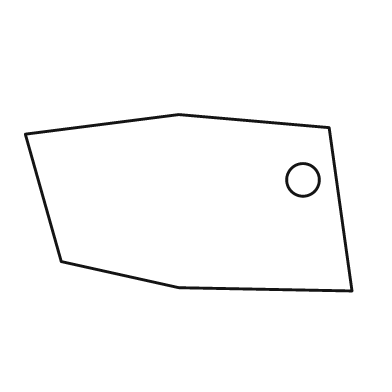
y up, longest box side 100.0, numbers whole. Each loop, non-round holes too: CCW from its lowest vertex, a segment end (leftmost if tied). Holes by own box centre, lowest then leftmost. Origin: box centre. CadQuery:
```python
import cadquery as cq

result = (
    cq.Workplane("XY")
    .moveTo(50.0, -27.0)
    .lineTo(43.0, 23.0)
    .lineTo(-3.0, 27.0)
    .lineTo(-50.0, 21.0)
    .lineTo(-39.0, -18.0)
    .lineTo(-3.0, -26.0)
    .close()
    .moveTo(35.0, 7.0)
    .circle(5.0)
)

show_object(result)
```